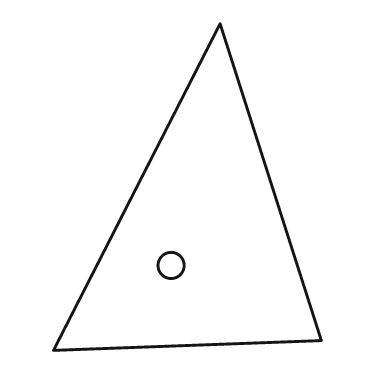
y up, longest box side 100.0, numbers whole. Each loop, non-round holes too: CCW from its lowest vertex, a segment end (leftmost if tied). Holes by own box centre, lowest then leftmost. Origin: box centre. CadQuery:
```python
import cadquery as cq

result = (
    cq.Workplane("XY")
    .moveTo(-41.0, -50.0)
    .lineTo(41.0, -47.0)
    .lineTo(10.0, 50.0)
    .close()
    .moveTo(-5.0, -24.0)
    .circle(4.0)
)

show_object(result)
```